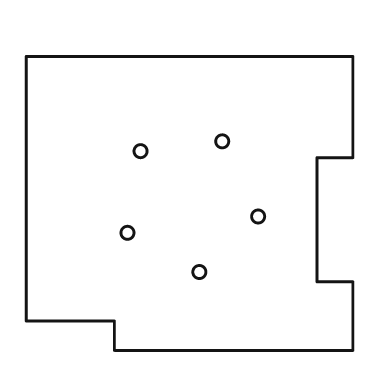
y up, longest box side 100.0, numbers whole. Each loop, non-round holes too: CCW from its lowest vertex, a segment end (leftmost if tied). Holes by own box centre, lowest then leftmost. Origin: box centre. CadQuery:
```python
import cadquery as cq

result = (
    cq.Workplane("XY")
    .moveTo(-23.0, -45.0)
    .lineTo(50.0, -45.0)
    .lineTo(50.0, -24.0)
    .lineTo(39.0, -24.0)
    .lineTo(39.0, 14.0)
    .lineTo(50.0, 14.0)
    .lineTo(50.0, 45.0)
    .lineTo(-50.0, 45.0)
    .lineTo(-50.0, -36.0)
    .lineTo(-23.0, -36.0)
    .close()
    .moveTo(3.0, -21.0)
    .circle(2.0)
    .moveTo(-19.0, -9.0)
    .circle(2.0)
    .moveTo(21.0, -4.0)
    .circle(2.0)
    .moveTo(-15.0, 16.0)
    .circle(2.0)
    .moveTo(10.0, 19.0)
    .circle(2.0)
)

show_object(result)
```